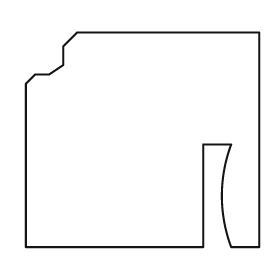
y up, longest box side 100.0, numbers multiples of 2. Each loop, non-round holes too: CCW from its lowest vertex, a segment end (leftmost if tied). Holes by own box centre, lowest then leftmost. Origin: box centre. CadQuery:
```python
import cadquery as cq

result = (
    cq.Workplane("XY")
    .moveTo(-50.0, -46.0)
    .lineTo(26.0, -46.0)
    .lineTo(26.0, -2.0)
    .lineTo(38.0, -2.0)
    .threePointArc((34.0, -24.0), (38.0, -46.0))
    .lineTo(50.0, -46.0)
    .lineTo(50.0, 46.0)
    .lineTo(-28.0, 46.0)
    .lineTo(-34.0, 40.0)
    .lineTo(-34.0, 32.0)
    .lineTo(-40.0, 28.0)
    .lineTo(-46.0, 28.0)
    .lineTo(-50.0, 24.0)
    .close()
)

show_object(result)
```